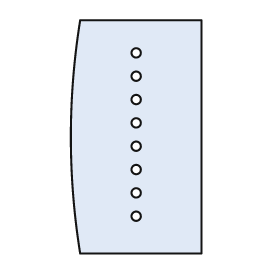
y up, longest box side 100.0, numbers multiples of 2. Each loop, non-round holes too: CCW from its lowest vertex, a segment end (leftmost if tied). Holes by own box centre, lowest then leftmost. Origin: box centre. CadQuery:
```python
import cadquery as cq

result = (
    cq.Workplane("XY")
    .moveTo(-24.0, -50.0)
    .lineTo(28.0, -50.0)
    .lineTo(28.0, 50.0)
    .lineTo(-24.0, 50.0)
    .threePointArc((-28.0, 0.0), (-24.0, -50.0))
    .close()
    .moveTo(0.0, -34.0)
    .circle(2.0)
    .moveTo(0.0, -24.0)
    .circle(2.0)
    .moveTo(0.0, -14.0)
    .circle(2.0)
    .moveTo(0.0, -4.0)
    .circle(2.0)
    .moveTo(0.0, 6.0)
    .circle(2.0)
    .moveTo(0.0, 16.0)
    .circle(2.0)
    .moveTo(0.0, 26.0)
    .circle(2.0)
    .moveTo(0.0, 36.0)
    .circle(2.0)
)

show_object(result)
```